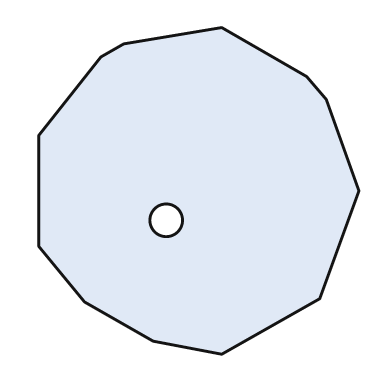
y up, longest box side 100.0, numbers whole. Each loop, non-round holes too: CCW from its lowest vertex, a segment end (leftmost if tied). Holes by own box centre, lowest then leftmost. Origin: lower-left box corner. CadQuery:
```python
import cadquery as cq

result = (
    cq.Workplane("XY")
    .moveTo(56.0, 0.0)
    .lineTo(86.0, 17.0)
    .lineTo(98.0, 50.0)
    .lineTo(88.0, 78.0)
    .lineTo(82.0, 85.0)
    .lineTo(56.0, 100.0)
    .lineTo(26.0, 95.0)
    .lineTo(19.0, 91.0)
    .lineTo(0.0, 67.0)
    .lineTo(0.0, 33.0)
    .lineTo(14.0, 16.0)
    .lineTo(35.0, 4.0)
    .close()
    .moveTo(39.0, 41.0)
    .circle(5.0)
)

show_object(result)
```